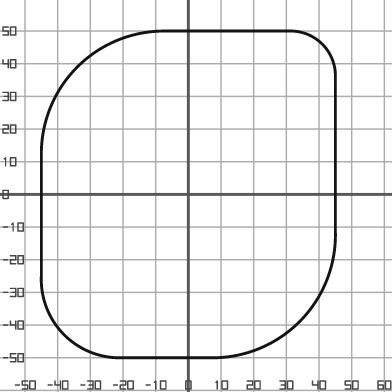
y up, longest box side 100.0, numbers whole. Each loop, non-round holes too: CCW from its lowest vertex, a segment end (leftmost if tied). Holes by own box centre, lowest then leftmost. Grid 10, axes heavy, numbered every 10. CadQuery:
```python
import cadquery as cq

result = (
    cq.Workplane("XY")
    .moveTo(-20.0, -50.0)
    .lineTo(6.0, -50.0)
    .threePointArc((34.0, -39.0), (45.0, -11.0))
    .lineTo(45.0, 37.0)
    .threePointArc((41.0, 46.0), (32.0, 50.0))
    .lineTo(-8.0, 50.0)
    .threePointArc((-34.0, 39.0), (-45.0, 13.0))
    .lineTo(-45.0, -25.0)
    .threePointArc((-38.0, -43.0), (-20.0, -50.0))
    .close()
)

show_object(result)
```